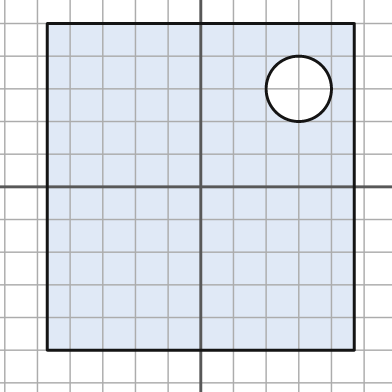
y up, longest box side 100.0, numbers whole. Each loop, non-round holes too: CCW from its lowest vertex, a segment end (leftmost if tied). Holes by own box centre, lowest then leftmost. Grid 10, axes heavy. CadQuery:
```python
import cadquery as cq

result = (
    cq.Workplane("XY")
    .moveTo(-47.0, -50.0)
    .lineTo(47.0, -50.0)
    .lineTo(47.0, 50.0)
    .lineTo(-47.0, 50.0)
    .close()
    .moveTo(30.0, 30.0)
    .circle(10.0)
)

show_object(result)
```